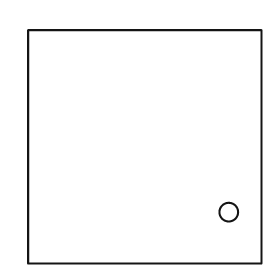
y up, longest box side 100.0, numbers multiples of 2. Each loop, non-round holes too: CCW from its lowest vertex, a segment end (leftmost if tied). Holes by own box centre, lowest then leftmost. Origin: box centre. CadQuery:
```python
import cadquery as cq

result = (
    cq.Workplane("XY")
    .moveTo(-50.0, -50.0)
    .lineTo(50.0, -50.0)
    .lineTo(50.0, 50.0)
    .lineTo(-50.0, 50.0)
    .close()
    .moveTo(36.0, -28.0)
    .circle(4.0)
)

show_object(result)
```